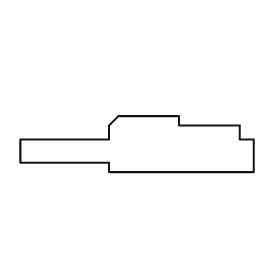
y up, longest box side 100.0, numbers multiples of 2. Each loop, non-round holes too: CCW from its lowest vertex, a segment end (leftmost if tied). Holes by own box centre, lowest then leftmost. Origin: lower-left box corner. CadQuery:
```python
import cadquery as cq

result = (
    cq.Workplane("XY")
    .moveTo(38.0, 0.0)
    .lineTo(100.0, 0.0)
    .lineTo(100.0, 14.0)
    .lineTo(94.0, 14.0)
    .lineTo(94.0, 20.0)
    .lineTo(68.0, 20.0)
    .lineTo(68.0, 24.0)
    .lineTo(42.0, 24.0)
    .lineTo(38.0, 20.0)
    .lineTo(38.0, 14.0)
    .lineTo(0.0, 14.0)
    .lineTo(0.0, 4.0)
    .lineTo(38.0, 4.0)
    .close()
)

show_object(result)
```